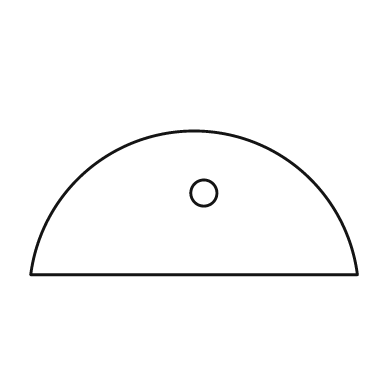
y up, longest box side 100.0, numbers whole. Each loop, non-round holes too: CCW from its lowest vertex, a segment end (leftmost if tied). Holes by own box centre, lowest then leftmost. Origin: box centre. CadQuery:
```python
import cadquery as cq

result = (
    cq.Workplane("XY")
    .moveTo(-50.0, -22.0)
    .lineTo(50.0, -22.0)
    .threePointArc((0.0, 22.0), (-50.0, -22.0))
    .close()
    .moveTo(3.0, 3.0)
    .circle(4.0)
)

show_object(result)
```